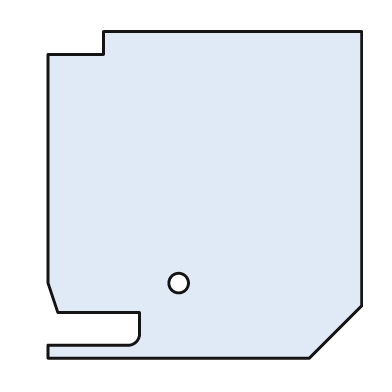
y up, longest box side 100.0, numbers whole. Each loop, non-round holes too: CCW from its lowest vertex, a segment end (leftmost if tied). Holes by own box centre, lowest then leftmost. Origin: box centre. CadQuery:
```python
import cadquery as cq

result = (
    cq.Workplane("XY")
    .moveTo(-48.0, -50.0)
    .lineTo(32.0, -50.0)
    .lineTo(48.0, -34.0)
    .lineTo(48.0, 50.0)
    .lineTo(-31.0, 50.0)
    .lineTo(-31.0, 43.0)
    .lineTo(-48.0, 43.0)
    .lineTo(-48.0, -27.0)
    .lineTo(-45.0, -36.0)
    .lineTo(-20.0, -36.0)
    .lineTo(-20.0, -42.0)
    .threePointArc((-21.0, -45.0), (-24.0, -46.0))
    .lineTo(-48.0, -46.0)
    .close()
    .moveTo(-8.0, -27.0)
    .circle(3.0)
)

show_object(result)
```